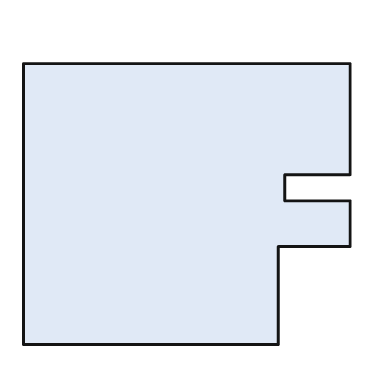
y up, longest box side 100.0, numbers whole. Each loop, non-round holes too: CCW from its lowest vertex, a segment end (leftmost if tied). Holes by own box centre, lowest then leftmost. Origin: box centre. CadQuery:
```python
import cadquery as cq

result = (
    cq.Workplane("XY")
    .moveTo(-50.0, -43.0)
    .lineTo(28.0, -43.0)
    .lineTo(28.0, -13.0)
    .lineTo(50.0, -13.0)
    .lineTo(50.0, 1.0)
    .lineTo(30.0, 1.0)
    .lineTo(30.0, 9.0)
    .lineTo(50.0, 9.0)
    .lineTo(50.0, 43.0)
    .lineTo(-50.0, 43.0)
    .close()
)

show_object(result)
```